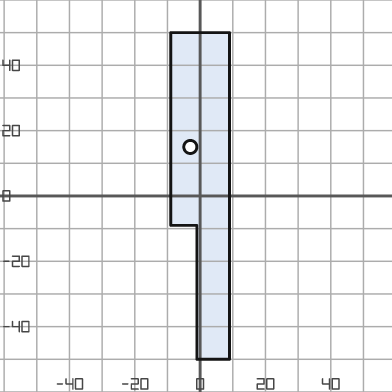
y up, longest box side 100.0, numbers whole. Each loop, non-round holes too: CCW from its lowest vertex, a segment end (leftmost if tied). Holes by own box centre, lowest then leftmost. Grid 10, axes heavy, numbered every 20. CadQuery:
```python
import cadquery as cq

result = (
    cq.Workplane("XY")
    .moveTo(-1.0, -50.0)
    .lineTo(9.0, -50.0)
    .lineTo(9.0, 50.0)
    .lineTo(-9.0, 50.0)
    .lineTo(-9.0, -9.0)
    .lineTo(-1.0, -9.0)
    .close()
    .moveTo(-3.0, 15.0)
    .circle(2.0)
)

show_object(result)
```